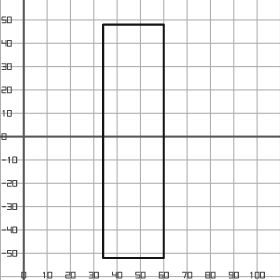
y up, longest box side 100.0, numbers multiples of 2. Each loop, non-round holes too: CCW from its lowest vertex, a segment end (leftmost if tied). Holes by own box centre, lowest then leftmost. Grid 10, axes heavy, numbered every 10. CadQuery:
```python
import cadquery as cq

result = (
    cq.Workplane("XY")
    .moveTo(34.0, -52.0)
    .lineTo(60.0, -52.0)
    .lineTo(60.0, 48.0)
    .lineTo(34.0, 48.0)
    .close()
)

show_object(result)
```